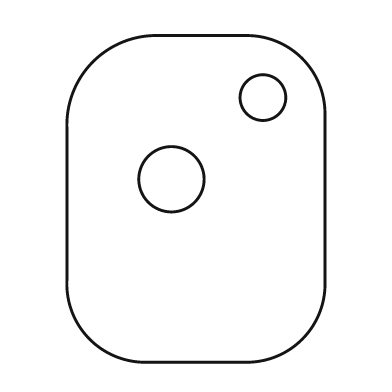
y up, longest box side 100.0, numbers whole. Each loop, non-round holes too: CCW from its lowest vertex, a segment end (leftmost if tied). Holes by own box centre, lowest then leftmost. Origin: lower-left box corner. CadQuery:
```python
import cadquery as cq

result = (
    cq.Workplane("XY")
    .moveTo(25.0, 0.0)
    .lineTo(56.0, 0.0)
    .threePointArc((72.0, 7.0), (79.0, 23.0))
    .lineTo(79.0, 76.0)
    .threePointArc((72.0, 93.0), (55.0, 100.0))
    .lineTo(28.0, 100.0)
    .threePointArc((8.0, 92.0), (0.0, 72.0))
    .lineTo(0.0, 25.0)
    .threePointArc((7.0, 7.0), (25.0, 0.0))
    .close()
    .moveTo(32.0, 56.0)
    .circle(10.0)
    .moveTo(60.0, 81.0)
    .circle(7.0)
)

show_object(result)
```